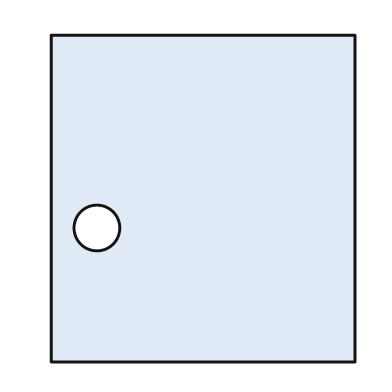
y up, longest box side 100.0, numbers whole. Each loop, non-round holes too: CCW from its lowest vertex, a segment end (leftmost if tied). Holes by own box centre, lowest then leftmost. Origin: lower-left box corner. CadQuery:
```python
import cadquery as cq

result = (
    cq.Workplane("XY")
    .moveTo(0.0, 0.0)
    .lineTo(93.0, 0.0)
    .lineTo(93.0, 100.0)
    .lineTo(0.0, 100.0)
    .close()
    .moveTo(14.0, 41.0)
    .circle(7.0)
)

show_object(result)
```